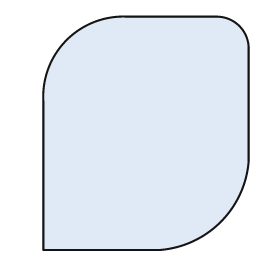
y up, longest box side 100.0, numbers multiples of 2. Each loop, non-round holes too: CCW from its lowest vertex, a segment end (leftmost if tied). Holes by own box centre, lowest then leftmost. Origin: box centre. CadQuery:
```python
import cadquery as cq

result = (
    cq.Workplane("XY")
    .moveTo(-44.0, -50.0)
    .lineTo(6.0, -50.0)
    .threePointArc((32.0, -38.0), (44.0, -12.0))
    .lineTo(44.0, 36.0)
    .threePointArc((40.0, 46.0), (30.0, 50.0))
    .lineTo(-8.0, 50.0)
    .threePointArc((-34.0, 40.0), (-44.0, 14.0))
    .close()
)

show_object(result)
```